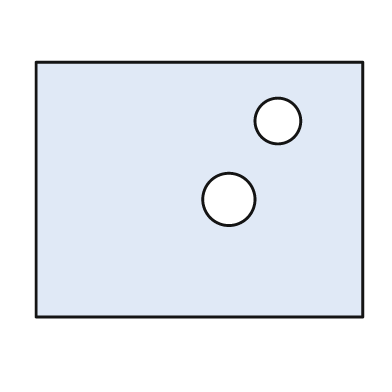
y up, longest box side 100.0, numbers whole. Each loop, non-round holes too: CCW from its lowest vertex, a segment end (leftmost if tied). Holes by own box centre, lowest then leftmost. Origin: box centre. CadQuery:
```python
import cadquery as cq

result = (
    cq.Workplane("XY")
    .moveTo(-50.0, -39.0)
    .lineTo(50.0, -39.0)
    .lineTo(50.0, 39.0)
    .lineTo(-50.0, 39.0)
    .close()
    .moveTo(9.0, -3.0)
    .circle(8.0)
    .moveTo(24.0, 21.0)
    .circle(7.0)
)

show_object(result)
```